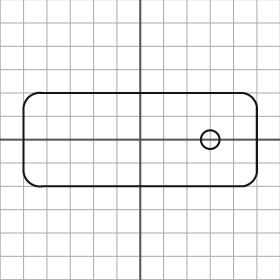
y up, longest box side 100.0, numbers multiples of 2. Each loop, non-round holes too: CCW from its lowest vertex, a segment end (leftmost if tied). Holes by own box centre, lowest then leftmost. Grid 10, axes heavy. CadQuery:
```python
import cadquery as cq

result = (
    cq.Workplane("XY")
    .moveTo(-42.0, -20.0)
    .lineTo(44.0, -20.0)
    .threePointArc((48.0, -18.0), (50.0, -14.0))
    .lineTo(50.0, 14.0)
    .threePointArc((48.0, 18.0), (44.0, 20.0))
    .lineTo(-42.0, 20.0)
    .threePointArc((-48.0, 18.0), (-50.0, 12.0))
    .lineTo(-50.0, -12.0)
    .threePointArc((-48.0, -18.0), (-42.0, -20.0))
    .close()
    .moveTo(30.0, 0.0)
    .circle(4.0)
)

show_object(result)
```